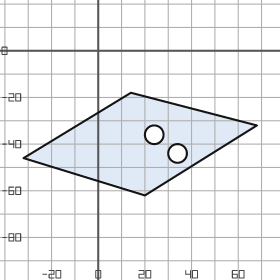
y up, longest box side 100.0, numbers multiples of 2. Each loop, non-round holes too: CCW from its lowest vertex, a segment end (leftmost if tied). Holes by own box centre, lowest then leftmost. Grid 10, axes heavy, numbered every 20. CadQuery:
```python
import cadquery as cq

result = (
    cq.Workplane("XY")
    .moveTo(20.0, -62.0)
    .lineTo(68.0, -32.0)
    .lineTo(14.0, -18.0)
    .lineTo(-32.0, -46.0)
    .close()
    .moveTo(34.0, -44.0)
    .circle(4.0)
    .moveTo(24.0, -36.0)
    .circle(4.0)
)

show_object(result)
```